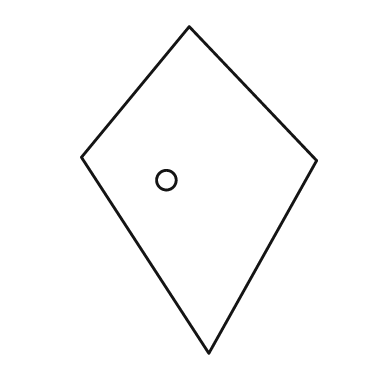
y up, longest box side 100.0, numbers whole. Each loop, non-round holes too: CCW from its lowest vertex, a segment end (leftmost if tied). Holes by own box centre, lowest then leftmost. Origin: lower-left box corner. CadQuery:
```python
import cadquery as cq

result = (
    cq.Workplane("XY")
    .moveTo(39.0, 0.0)
    .lineTo(72.0, 59.0)
    .lineTo(33.0, 100.0)
    .lineTo(0.0, 60.0)
    .close()
    .moveTo(26.0, 53.0)
    .circle(3.0)
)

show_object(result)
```